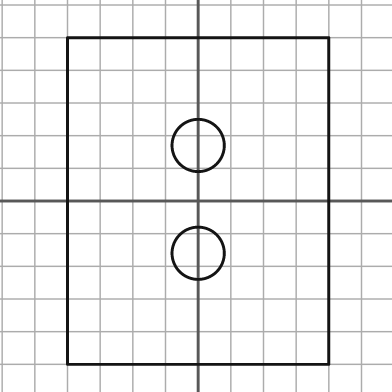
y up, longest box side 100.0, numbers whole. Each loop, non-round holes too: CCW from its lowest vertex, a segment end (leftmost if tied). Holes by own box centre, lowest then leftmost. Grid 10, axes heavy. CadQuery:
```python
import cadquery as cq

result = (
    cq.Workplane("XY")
    .moveTo(-40.0, -50.0)
    .lineTo(40.0, -50.0)
    .lineTo(40.0, 50.0)
    .lineTo(-40.0, 50.0)
    .close()
    .moveTo(0.0, -16.0)
    .circle(8.0)
    .moveTo(0.0, 17.0)
    .circle(8.0)
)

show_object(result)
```